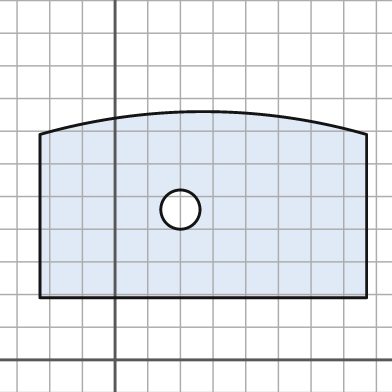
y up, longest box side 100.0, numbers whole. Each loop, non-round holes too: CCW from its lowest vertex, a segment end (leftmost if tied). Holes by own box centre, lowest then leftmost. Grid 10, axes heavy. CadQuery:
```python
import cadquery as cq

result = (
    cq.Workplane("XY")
    .moveTo(-23.0, 19.0)
    .lineTo(77.0, 19.0)
    .lineTo(77.0, 69.0)
    .threePointArc((27.0, 76.0), (-23.0, 69.0))
    .close()
    .moveTo(20.0, 46.0)
    .circle(6.0)
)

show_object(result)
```